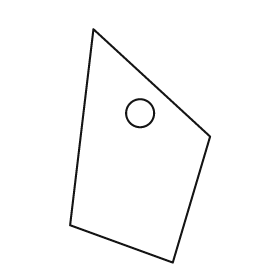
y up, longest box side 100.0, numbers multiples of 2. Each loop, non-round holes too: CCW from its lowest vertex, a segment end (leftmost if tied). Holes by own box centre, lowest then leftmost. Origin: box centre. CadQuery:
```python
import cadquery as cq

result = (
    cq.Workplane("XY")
    .moveTo(14.0, -50.0)
    .lineTo(30.0, 4.0)
    .lineTo(-20.0, 50.0)
    .lineTo(-30.0, -34.0)
    .close()
    .moveTo(0.0, 14.0)
    .circle(6.0)
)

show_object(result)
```